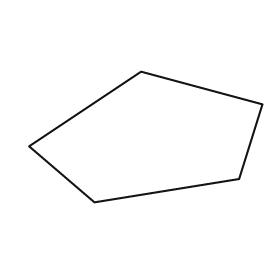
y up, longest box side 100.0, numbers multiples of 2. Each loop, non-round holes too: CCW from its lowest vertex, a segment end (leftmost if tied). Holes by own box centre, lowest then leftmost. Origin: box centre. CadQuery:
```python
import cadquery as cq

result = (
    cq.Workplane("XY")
    .moveTo(-22.0, -28.0)
    .lineTo(40.0, -18.0)
    .lineTo(50.0, 14.0)
    .lineTo(-2.0, 28.0)
    .lineTo(-50.0, -4.0)
    .close()
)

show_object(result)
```